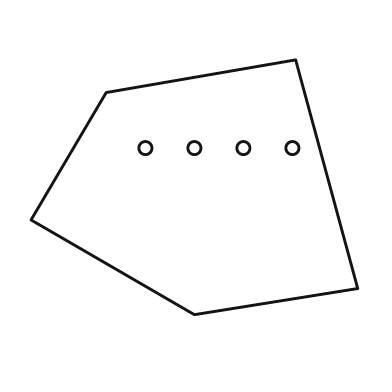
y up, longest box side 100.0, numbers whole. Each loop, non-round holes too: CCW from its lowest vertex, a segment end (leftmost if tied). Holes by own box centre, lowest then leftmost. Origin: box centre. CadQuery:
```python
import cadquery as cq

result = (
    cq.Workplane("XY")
    .moveTo(0.0, -39.0)
    .lineTo(50.0, -31.0)
    .lineTo(31.0, 39.0)
    .lineTo(-27.0, 29.0)
    .lineTo(-50.0, -10.0)
    .close()
    .moveTo(-15.0, 12.0)
    .circle(2.0)
    .moveTo(0.0, 12.0)
    .circle(2.0)
    .moveTo(15.0, 12.0)
    .circle(2.0)
    .moveTo(30.0, 12.0)
    .circle(2.0)
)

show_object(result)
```